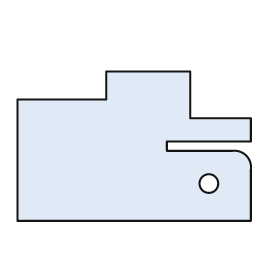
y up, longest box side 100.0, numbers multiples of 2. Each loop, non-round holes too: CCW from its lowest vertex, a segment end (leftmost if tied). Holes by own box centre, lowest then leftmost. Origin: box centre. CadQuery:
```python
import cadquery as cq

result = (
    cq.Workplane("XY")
    .moveTo(-50.0, -32.0)
    .lineTo(50.0, -32.0)
    .lineTo(50.0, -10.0)
    .threePointArc((48.0, -4.0), (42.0, -2.0))
    .lineTo(14.0, -2.0)
    .lineTo(14.0, 2.0)
    .lineTo(50.0, 2.0)
    .lineTo(50.0, 12.0)
    .lineTo(24.0, 12.0)
    .lineTo(24.0, 32.0)
    .lineTo(-12.0, 32.0)
    .lineTo(-12.0, 20.0)
    .lineTo(-50.0, 20.0)
    .close()
    .moveTo(32.0, -16.0)
    .circle(4.0)
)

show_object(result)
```